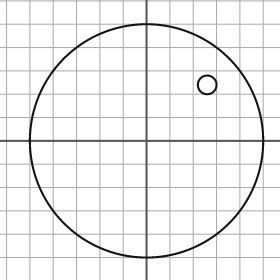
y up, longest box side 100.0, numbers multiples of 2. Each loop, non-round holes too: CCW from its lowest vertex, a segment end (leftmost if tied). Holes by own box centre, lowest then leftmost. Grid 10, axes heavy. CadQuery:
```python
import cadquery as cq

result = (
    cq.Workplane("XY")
    .moveTo(0.0, 0.0)
    .circle(50.0)
    .moveTo(26.0, 24.0)
    .circle(4.0)
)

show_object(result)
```